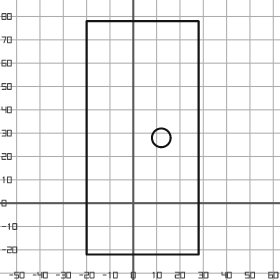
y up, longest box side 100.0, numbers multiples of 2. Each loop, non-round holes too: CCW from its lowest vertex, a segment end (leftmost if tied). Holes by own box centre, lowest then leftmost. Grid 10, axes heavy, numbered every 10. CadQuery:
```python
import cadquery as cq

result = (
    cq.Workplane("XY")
    .moveTo(-20.0, -22.0)
    .lineTo(28.0, -22.0)
    .lineTo(28.0, 78.0)
    .lineTo(-20.0, 78.0)
    .close()
    .moveTo(12.0, 28.0)
    .circle(4.0)
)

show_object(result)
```